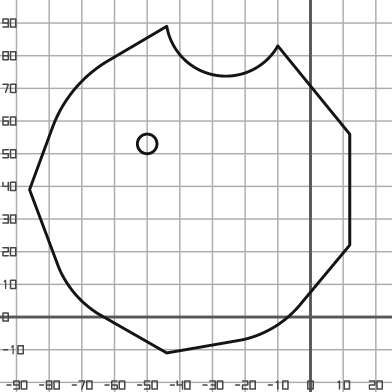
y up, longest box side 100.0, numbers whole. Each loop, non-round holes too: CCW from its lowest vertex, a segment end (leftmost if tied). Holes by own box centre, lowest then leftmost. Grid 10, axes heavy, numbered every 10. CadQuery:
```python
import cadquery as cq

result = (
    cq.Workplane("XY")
    .moveTo(-44.0, -11.0)
    .lineTo(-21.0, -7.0)
    .threePointArc((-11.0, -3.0), (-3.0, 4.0))
    .lineTo(12.0, 22.0)
    .lineTo(12.0, 56.0)
    .lineTo(-10.0, 83.0)
    .threePointArc((-29.0, 74.0), (-44.0, 89.0))
    .lineTo(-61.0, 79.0)
    .threePointArc((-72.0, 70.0), (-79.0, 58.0))
    .lineTo(-86.0, 39.0)
    .lineTo(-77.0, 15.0)
    .threePointArc((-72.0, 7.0), (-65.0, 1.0))
    .close()
    .moveTo(-50.0, 53.0)
    .circle(3.0)
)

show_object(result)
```